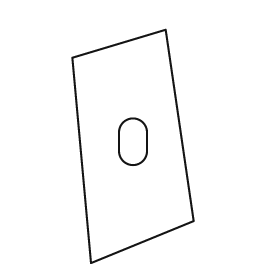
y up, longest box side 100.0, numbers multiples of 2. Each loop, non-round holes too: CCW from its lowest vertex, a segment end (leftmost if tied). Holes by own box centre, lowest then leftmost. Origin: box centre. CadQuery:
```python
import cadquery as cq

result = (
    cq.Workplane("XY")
    .moveTo(-18.0, -50.0)
    .lineTo(26.0, -32.0)
    .lineTo(14.0, 50.0)
    .lineTo(-26.0, 38.0)
    .close()
    .moveTo(-6.0, -2.0)
    .threePointArc((0.0, -8.0), (6.0, -2.0))
    .lineTo(6.0, 6.0)
    .threePointArc((0.0, 12.0), (-6.0, 6.0))
    .close()
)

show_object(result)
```